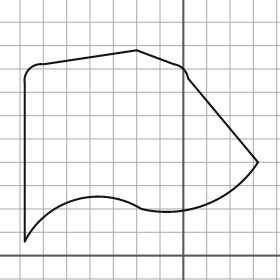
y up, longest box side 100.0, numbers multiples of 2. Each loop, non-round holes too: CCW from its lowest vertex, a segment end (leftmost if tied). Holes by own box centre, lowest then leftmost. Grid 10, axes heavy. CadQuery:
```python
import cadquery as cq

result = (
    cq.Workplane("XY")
    .moveTo(-68.0, 6.0)
    .threePointArc((-46.0, 24.0), (-18.0, 20.0))
    .threePointArc((10.0, 22.0), (32.0, 40.0))
    .lineTo(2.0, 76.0)
    .threePointArc((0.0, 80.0), (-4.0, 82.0))
    .lineTo(-20.0, 88.0)
    .lineTo(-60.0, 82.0)
    .threePointArc((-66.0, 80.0), (-68.0, 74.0))
    .close()
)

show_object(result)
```